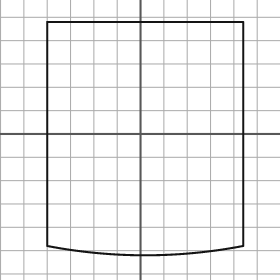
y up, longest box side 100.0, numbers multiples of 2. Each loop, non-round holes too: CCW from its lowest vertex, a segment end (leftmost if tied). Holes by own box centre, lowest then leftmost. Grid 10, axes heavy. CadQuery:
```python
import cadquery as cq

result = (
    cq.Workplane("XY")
    .moveTo(-40.0, -48.0)
    .threePointArc((2.0, -52.0), (44.0, -48.0))
    .lineTo(44.0, 48.0)
    .lineTo(-40.0, 48.0)
    .close()
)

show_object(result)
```